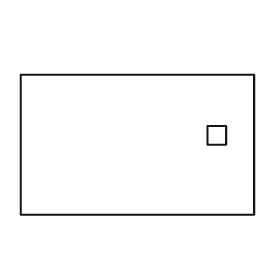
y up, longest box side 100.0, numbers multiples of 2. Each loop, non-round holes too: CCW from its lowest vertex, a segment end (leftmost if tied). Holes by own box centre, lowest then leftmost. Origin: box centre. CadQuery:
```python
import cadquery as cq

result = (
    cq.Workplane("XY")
    .moveTo(-50.0, -30.0)
    .lineTo(50.0, -30.0)
    .lineTo(50.0, 30.0)
    .lineTo(-50.0, 30.0)
    .close()
    .moveTo(30.0, 0.0)
    .lineTo(38.0, 0.0)
    .lineTo(38.0, 8.0)
    .lineTo(30.0, 8.0)
    .close()
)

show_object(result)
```